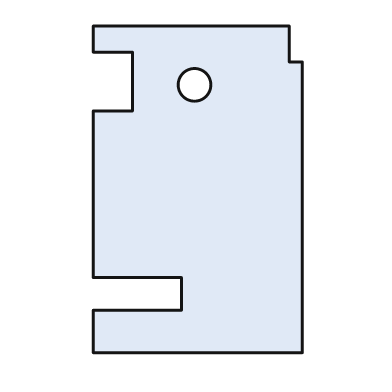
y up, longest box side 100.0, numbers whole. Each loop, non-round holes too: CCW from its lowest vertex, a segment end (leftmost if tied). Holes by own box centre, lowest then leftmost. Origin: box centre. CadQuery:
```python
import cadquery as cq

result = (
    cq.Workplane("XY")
    .moveTo(-32.0, -50.0)
    .lineTo(32.0, -50.0)
    .lineTo(32.0, 39.0)
    .lineTo(28.0, 39.0)
    .lineTo(28.0, 50.0)
    .lineTo(-32.0, 50.0)
    .lineTo(-32.0, 42.0)
    .lineTo(-20.0, 42.0)
    .lineTo(-20.0, 24.0)
    .lineTo(-32.0, 24.0)
    .lineTo(-32.0, -27.0)
    .lineTo(-5.0, -27.0)
    .lineTo(-5.0, -37.0)
    .lineTo(-32.0, -37.0)
    .close()
    .moveTo(-1.0, 32.0)
    .circle(5.0)
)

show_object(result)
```